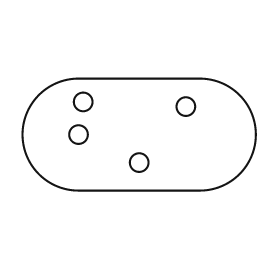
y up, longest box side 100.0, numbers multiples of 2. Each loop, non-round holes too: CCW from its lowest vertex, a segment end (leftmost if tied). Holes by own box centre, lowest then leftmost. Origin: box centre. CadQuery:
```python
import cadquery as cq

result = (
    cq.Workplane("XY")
    .moveTo(-26.0, -24.0)
    .lineTo(26.0, -24.0)
    .threePointArc((50.0, 0.0), (26.0, 24.0))
    .lineTo(-26.0, 24.0)
    .threePointArc((-50.0, 0.0), (-26.0, -24.0))
    .close()
    .moveTo(0.0, -12.0)
    .circle(4.0)
    .moveTo(-26.0, 0.0)
    .circle(4.0)
    .moveTo(20.0, 12.0)
    .circle(4.0)
    .moveTo(-24.0, 14.0)
    .circle(4.0)
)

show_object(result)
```